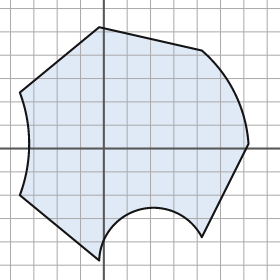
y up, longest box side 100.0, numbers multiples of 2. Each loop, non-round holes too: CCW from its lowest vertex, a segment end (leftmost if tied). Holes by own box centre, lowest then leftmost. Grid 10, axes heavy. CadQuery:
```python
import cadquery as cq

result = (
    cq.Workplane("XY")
    .moveTo(-2.0, -48.0)
    .threePointArc((16.0, -26.0), (42.0, -38.0))
    .lineTo(62.0, 2.0)
    .threePointArc((56.0, 24.0), (42.0, 42.0))
    .lineTo(-2.0, 52.0)
    .lineTo(-36.0, 24.0)
    .threePointArc((-32.0, 2.0), (-36.0, -20.0))
    .close()
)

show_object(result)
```